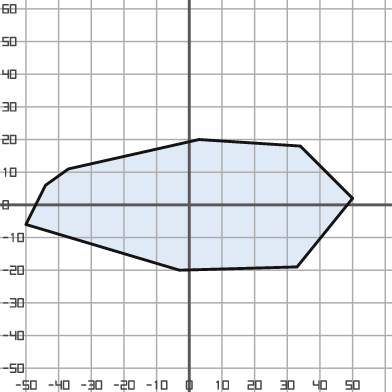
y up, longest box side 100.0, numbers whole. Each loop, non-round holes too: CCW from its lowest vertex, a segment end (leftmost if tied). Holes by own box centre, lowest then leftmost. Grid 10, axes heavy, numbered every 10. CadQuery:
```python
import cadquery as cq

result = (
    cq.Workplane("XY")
    .moveTo(-3.0, -20.0)
    .lineTo(33.0, -19.0)
    .lineTo(50.0, 2.0)
    .lineTo(34.0, 18.0)
    .lineTo(3.0, 20.0)
    .lineTo(-37.0, 11.0)
    .lineTo(-44.0, 6.0)
    .lineTo(-50.0, -6.0)
    .close()
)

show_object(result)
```